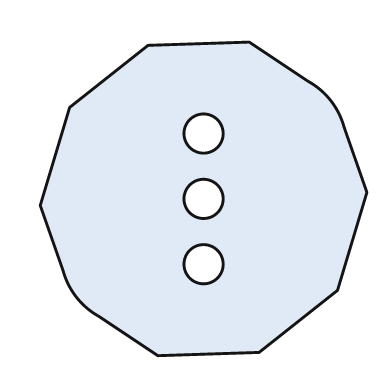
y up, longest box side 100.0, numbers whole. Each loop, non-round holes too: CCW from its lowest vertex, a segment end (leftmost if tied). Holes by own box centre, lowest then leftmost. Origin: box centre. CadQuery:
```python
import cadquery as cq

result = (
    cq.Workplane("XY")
    .moveTo(-14.0, -48.0)
    .lineTo(17.0, -47.0)
    .lineTo(41.0, -28.0)
    .lineTo(50.0, 2.0)
    .lineTo(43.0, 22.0)
    .threePointArc((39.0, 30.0), (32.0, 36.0))
    .lineTo(14.0, 48.0)
    .lineTo(-17.0, 47.0)
    .lineTo(-41.0, 28.0)
    .lineTo(-50.0, -2.0)
    .lineTo(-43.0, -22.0)
    .threePointArc((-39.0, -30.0), (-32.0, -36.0))
    .close()
    .moveTo(0.0, -20.0)
    .circle(6.0)
    .moveTo(0.0, 0.0)
    .circle(6.0)
    .moveTo(0.0, 20.0)
    .circle(6.0)
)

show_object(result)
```